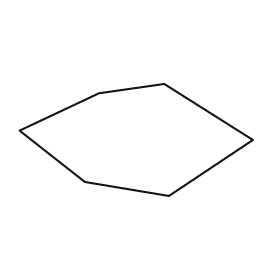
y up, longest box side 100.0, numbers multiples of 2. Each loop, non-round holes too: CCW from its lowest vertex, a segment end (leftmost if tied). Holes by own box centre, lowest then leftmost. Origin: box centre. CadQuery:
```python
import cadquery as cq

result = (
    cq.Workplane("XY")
    .moveTo(14.0, -24.0)
    .lineTo(50.0, 0.0)
    .lineTo(12.0, 24.0)
    .lineTo(-16.0, 20.0)
    .lineTo(-50.0, 4.0)
    .lineTo(-22.0, -18.0)
    .close()
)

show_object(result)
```